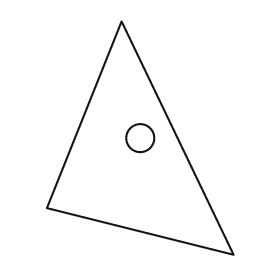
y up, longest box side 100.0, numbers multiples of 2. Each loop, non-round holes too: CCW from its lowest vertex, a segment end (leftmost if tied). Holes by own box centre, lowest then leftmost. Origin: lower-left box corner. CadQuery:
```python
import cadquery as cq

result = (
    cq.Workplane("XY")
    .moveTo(80.0, 0.0)
    .lineTo(32.0, 100.0)
    .lineTo(0.0, 20.0)
    .close()
    .moveTo(40.0, 50.0)
    .circle(6.0)
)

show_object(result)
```